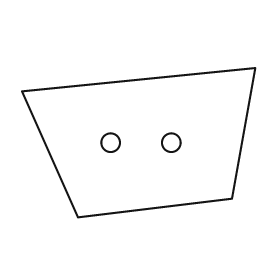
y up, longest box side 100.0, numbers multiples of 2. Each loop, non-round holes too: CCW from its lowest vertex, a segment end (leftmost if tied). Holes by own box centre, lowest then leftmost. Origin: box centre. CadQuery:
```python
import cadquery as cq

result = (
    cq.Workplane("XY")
    .moveTo(-26.0, -32.0)
    .lineTo(40.0, -24.0)
    .lineTo(50.0, 32.0)
    .lineTo(-50.0, 22.0)
    .close()
    .moveTo(-12.0, 0.0)
    .circle(4.0)
    .moveTo(14.0, 0.0)
    .circle(4.0)
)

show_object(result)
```